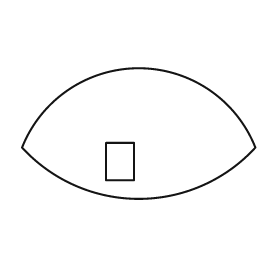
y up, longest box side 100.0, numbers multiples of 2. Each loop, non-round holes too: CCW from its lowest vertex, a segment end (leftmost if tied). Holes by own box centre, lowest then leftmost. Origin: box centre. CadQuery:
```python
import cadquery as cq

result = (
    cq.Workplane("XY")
    .moveTo(-50.0, -6.0)
    .threePointArc((0.0, -28.0), (50.0, -6.0))
    .threePointArc((0.0, 28.0), (-50.0, -6.0))
    .close()
    .moveTo(-14.0, -20.0)
    .lineTo(-2.0, -20.0)
    .lineTo(-2.0, -4.0)
    .lineTo(-14.0, -4.0)
    .close()
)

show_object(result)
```